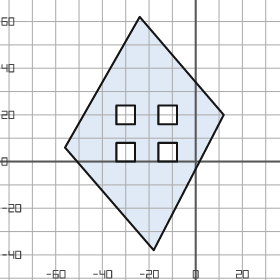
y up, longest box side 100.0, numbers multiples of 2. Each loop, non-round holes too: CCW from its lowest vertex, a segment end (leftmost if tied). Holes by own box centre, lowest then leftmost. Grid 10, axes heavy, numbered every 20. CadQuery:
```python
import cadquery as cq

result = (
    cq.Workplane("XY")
    .moveTo(-18.0, -38.0)
    .lineTo(12.0, 20.0)
    .lineTo(-24.0, 62.0)
    .lineTo(-56.0, 6.0)
    .close()
    .moveTo(-34.0, 0.0)
    .lineTo(-26.0, 0.0)
    .lineTo(-26.0, 8.0)
    .lineTo(-34.0, 8.0)
    .close()
    .moveTo(-16.0, 0.0)
    .lineTo(-8.0, 0.0)
    .lineTo(-8.0, 8.0)
    .lineTo(-16.0, 8.0)
    .close()
    .moveTo(-34.0, 16.0)
    .lineTo(-26.0, 16.0)
    .lineTo(-26.0, 24.0)
    .lineTo(-34.0, 24.0)
    .close()
    .moveTo(-16.0, 16.0)
    .lineTo(-8.0, 16.0)
    .lineTo(-8.0, 24.0)
    .lineTo(-16.0, 24.0)
    .close()
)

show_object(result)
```